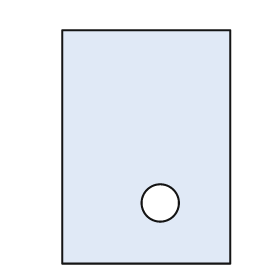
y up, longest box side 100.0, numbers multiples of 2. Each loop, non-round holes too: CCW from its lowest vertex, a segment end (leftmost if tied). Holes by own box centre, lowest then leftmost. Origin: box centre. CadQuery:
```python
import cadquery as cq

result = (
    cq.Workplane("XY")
    .moveTo(-36.0, -50.0)
    .lineTo(36.0, -50.0)
    .lineTo(36.0, 50.0)
    .lineTo(-36.0, 50.0)
    .close()
    .moveTo(6.0, -24.0)
    .circle(8.0)
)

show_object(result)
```